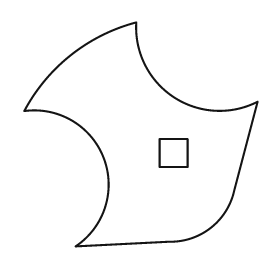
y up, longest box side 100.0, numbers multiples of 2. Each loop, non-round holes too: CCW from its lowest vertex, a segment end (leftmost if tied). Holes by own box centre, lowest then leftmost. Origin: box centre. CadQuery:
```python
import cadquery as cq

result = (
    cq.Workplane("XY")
    .moveTo(-28.0, -48.0)
    .lineTo(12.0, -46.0)
    .threePointArc((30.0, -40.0), (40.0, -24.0))
    .lineTo(50.0, 14.0)
    .threePointArc((14.0, 16.0), (-2.0, 48.0))
    .threePointArc((-30.0, 34.0), (-50.0, 10.0))
    .threePointArc((-16.0, -10.0), (-28.0, -48.0))
    .close()
    .moveTo(8.0, -14.0)
    .lineTo(20.0, -14.0)
    .lineTo(20.0, -2.0)
    .lineTo(8.0, -2.0)
    .close()
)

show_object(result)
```